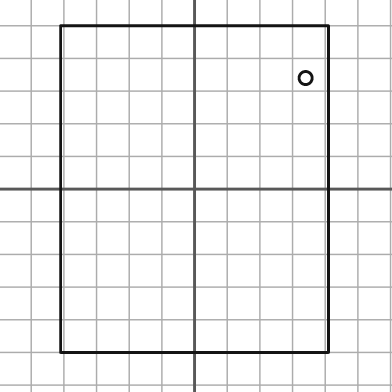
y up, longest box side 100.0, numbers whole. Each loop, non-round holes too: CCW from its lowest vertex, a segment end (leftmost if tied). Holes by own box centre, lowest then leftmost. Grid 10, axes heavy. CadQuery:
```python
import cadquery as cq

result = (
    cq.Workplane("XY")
    .moveTo(-41.0, -50.0)
    .lineTo(41.0, -50.0)
    .lineTo(41.0, 50.0)
    .lineTo(-41.0, 50.0)
    .close()
    .moveTo(34.0, 34.0)
    .circle(2.0)
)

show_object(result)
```